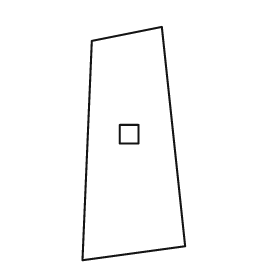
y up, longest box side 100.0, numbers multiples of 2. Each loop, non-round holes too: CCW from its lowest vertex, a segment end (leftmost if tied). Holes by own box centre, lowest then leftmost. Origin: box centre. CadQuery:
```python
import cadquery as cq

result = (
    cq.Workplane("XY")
    .moveTo(-22.0, -50.0)
    .lineTo(22.0, -44.0)
    .lineTo(12.0, 50.0)
    .lineTo(-18.0, 44.0)
    .close()
    .moveTo(-6.0, 0.0)
    .lineTo(2.0, 0.0)
    .lineTo(2.0, 8.0)
    .lineTo(-6.0, 8.0)
    .close()
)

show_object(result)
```